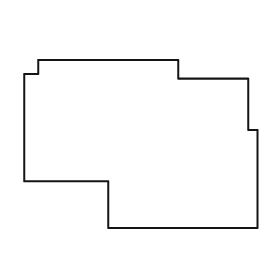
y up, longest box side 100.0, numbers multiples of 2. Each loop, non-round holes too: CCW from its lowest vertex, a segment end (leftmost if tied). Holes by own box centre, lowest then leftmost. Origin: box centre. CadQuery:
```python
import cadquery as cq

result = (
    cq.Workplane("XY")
    .moveTo(-14.0, -36.0)
    .lineTo(50.0, -36.0)
    .lineTo(50.0, 6.0)
    .lineTo(46.0, 6.0)
    .lineTo(46.0, 28.0)
    .lineTo(16.0, 28.0)
    .lineTo(16.0, 36.0)
    .lineTo(-44.0, 36.0)
    .lineTo(-44.0, 30.0)
    .lineTo(-50.0, 30.0)
    .lineTo(-50.0, -16.0)
    .lineTo(-14.0, -16.0)
    .close()
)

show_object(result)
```